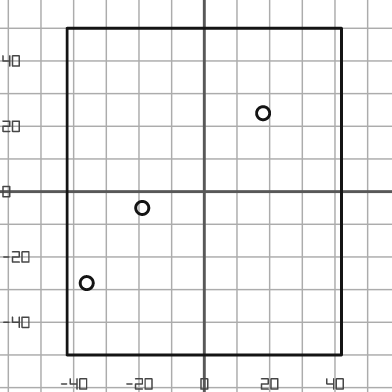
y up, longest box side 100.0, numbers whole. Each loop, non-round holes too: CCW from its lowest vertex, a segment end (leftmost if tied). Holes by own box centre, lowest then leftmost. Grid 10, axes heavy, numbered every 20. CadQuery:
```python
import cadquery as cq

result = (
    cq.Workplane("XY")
    .moveTo(-42.0, -50.0)
    .lineTo(42.0, -50.0)
    .lineTo(42.0, 50.0)
    .lineTo(-42.0, 50.0)
    .close()
    .moveTo(-36.0, -28.0)
    .circle(2.0)
    .moveTo(-19.0, -5.0)
    .circle(2.0)
    .moveTo(18.0, 24.0)
    .circle(2.0)
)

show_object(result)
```